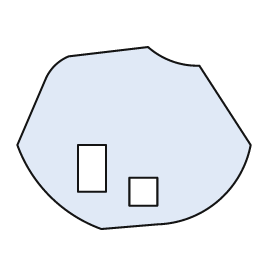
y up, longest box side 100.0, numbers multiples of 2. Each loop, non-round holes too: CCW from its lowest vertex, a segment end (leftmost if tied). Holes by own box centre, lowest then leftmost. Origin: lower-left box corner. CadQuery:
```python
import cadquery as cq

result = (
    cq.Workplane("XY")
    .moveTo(36.0, 0.0)
    .lineTo(60.0, 2.0)
    .threePointArc((86.0, 12.0), (100.0, 36.0))
    .lineTo(78.0, 70.0)
    .threePointArc((66.0, 72.0), (56.0, 78.0))
    .lineTo(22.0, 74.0)
    .threePointArc((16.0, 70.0), (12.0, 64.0))
    .lineTo(0.0, 36.0)
    .threePointArc((14.0, 14.0), (36.0, 0.0))
    .close()
    .moveTo(48.0, 10.0)
    .lineTo(60.0, 10.0)
    .lineTo(60.0, 22.0)
    .lineTo(48.0, 22.0)
    .close()
    .moveTo(26.0, 16.0)
    .lineTo(38.0, 16.0)
    .lineTo(38.0, 36.0)
    .lineTo(26.0, 36.0)
    .close()
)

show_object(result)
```